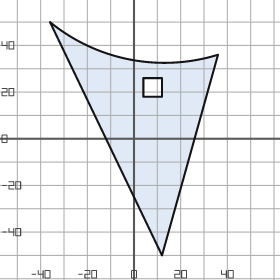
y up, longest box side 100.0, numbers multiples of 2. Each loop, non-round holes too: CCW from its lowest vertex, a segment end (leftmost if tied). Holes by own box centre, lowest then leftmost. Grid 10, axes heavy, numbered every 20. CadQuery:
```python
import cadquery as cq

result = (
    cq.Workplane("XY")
    .moveTo(12.0, -50.0)
    .lineTo(36.0, 36.0)
    .threePointArc((-2.0, 34.0), (-36.0, 50.0))
    .close()
    .moveTo(4.0, 18.0)
    .lineTo(12.0, 18.0)
    .lineTo(12.0, 26.0)
    .lineTo(4.0, 26.0)
    .close()
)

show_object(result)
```